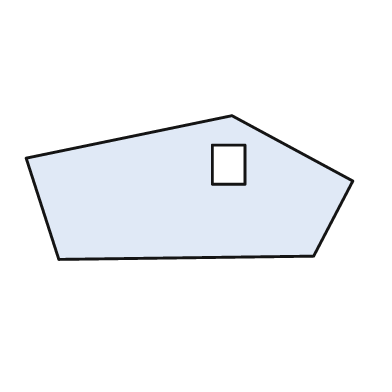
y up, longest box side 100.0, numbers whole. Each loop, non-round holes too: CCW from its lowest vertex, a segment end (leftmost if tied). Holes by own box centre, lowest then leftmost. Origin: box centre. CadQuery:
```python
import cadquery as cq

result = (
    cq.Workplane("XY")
    .moveTo(-40.0, -22.0)
    .lineTo(38.0, -21.0)
    .lineTo(50.0, 2.0)
    .lineTo(13.0, 22.0)
    .lineTo(-50.0, 9.0)
    .close()
    .moveTo(7.0, 1.0)
    .lineTo(17.0, 1.0)
    .lineTo(17.0, 13.0)
    .lineTo(7.0, 13.0)
    .close()
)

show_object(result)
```